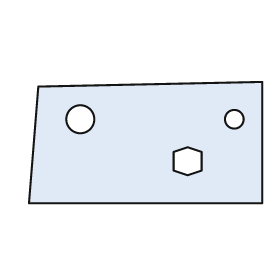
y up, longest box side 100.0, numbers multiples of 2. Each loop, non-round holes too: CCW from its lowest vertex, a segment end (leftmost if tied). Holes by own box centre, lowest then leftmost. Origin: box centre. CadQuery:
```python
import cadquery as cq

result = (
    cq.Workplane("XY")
    .moveTo(-50.0, -26.0)
    .lineTo(50.0, -26.0)
    .lineTo(50.0, 26.0)
    .lineTo(-46.0, 24.0)
    .close()
    .moveTo(18.0, -14.0)
    .lineTo(24.0, -12.0)
    .lineTo(24.0, -4.0)
    .lineTo(18.0, -2.0)
    .lineTo(12.0, -4.0)
    .lineTo(12.0, -12.0)
    .close()
    .moveTo(-28.0, 10.0)
    .circle(6.0)
    .moveTo(38.0, 10.0)
    .circle(4.0)
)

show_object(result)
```